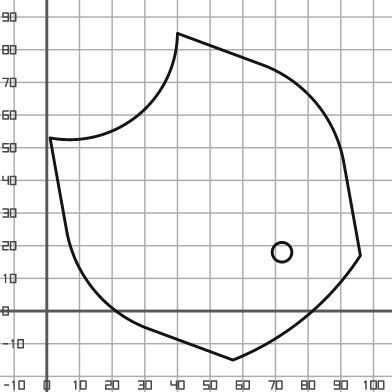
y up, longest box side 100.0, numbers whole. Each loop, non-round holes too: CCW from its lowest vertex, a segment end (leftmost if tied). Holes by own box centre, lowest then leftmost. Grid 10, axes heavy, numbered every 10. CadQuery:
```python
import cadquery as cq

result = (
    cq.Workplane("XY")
    .moveTo(57.0, -15.0)
    .threePointArc((79.0, -2.0), (96.0, 17.0))
    .lineTo(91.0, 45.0)
    .threePointArc((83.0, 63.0), (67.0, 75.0))
    .lineTo(40.0, 85.0)
    .threePointArc((28.0, 60.0), (1.0, 53.0))
    .lineTo(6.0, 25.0)
    .threePointArc((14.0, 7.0), (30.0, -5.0))
    .close()
    .moveTo(72.0, 18.0)
    .circle(3.0)
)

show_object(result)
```